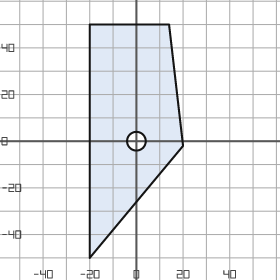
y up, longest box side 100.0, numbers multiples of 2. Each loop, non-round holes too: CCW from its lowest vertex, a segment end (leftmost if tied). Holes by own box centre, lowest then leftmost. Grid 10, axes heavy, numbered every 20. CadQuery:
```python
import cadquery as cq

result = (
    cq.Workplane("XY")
    .moveTo(-20.0, -50.0)
    .lineTo(20.0, -2.0)
    .lineTo(14.0, 50.0)
    .lineTo(-20.0, 50.0)
    .close()
    .moveTo(0.0, 0.0)
    .circle(4.0)
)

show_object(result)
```